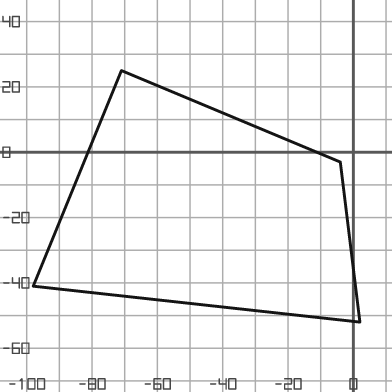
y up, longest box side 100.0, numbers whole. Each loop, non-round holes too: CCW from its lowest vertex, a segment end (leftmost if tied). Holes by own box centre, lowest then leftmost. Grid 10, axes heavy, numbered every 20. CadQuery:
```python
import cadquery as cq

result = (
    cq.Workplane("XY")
    .moveTo(2.0, -52.0)
    .lineTo(-4.0, -3.0)
    .lineTo(-71.0, 25.0)
    .lineTo(-98.0, -41.0)
    .close()
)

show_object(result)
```